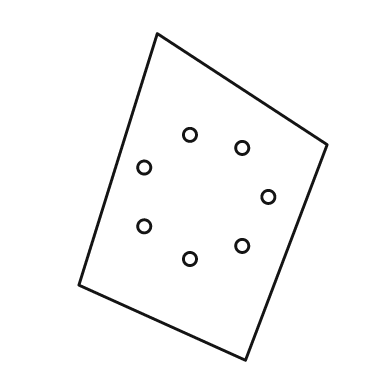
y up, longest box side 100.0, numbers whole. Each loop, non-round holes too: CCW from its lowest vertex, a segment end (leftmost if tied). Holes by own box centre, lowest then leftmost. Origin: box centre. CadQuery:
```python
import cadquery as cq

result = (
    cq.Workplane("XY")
    .moveTo(13.0, -50.0)
    .lineTo(38.0, 16.0)
    .lineTo(-14.0, 50.0)
    .lineTo(-38.0, -27.0)
    .close()
    .moveTo(-4.0, -19.0)
    .circle(2.0)
    .moveTo(12.0, -15.0)
    .circle(2.0)
    .moveTo(-18.0, -9.0)
    .circle(2.0)
    .moveTo(20.0, 0.0)
    .circle(2.0)
    .moveTo(-18.0, 9.0)
    .circle(2.0)
    .moveTo(12.0, 15.0)
    .circle(2.0)
    .moveTo(-4.0, 19.0)
    .circle(2.0)
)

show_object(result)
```